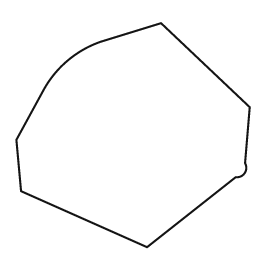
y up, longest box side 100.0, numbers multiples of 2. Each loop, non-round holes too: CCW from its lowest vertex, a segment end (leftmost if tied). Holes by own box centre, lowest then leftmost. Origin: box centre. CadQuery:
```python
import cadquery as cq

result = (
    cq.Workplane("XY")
    .moveTo(6.0, -48.0)
    .lineTo(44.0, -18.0)
    .threePointArc((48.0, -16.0), (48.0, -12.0))
    .lineTo(50.0, 12.0)
    .lineTo(12.0, 48.0)
    .lineTo(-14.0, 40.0)
    .threePointArc((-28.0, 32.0), (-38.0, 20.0))
    .lineTo(-50.0, -2.0)
    .lineTo(-48.0, -24.0)
    .close()
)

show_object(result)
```